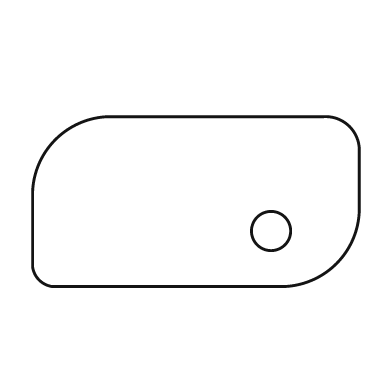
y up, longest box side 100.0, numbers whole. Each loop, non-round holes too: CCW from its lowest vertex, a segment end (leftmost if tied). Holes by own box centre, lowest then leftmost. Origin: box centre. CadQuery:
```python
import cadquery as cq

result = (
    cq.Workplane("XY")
    .moveTo(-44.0, -26.0)
    .lineTo(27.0, -26.0)
    .threePointArc((43.0, -19.0), (50.0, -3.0))
    .lineTo(50.0, 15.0)
    .threePointArc((47.0, 23.0), (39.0, 26.0))
    .lineTo(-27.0, 26.0)
    .threePointArc((-43.0, 19.0), (-50.0, 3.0))
    .lineTo(-50.0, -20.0)
    .threePointArc((-48.0, -24.0), (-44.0, -26.0))
    .close()
    .moveTo(23.0, -9.0)
    .circle(6.0)
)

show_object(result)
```